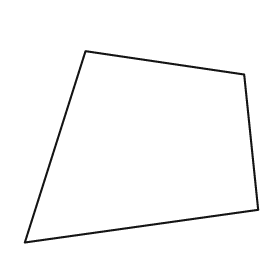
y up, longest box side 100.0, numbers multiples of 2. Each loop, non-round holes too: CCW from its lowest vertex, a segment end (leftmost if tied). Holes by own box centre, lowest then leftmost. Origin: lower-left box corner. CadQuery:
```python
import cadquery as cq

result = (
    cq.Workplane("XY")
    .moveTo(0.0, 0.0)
    .lineTo(100.0, 14.0)
    .lineTo(94.0, 72.0)
    .lineTo(26.0, 82.0)
    .close()
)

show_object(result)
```